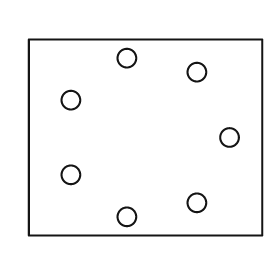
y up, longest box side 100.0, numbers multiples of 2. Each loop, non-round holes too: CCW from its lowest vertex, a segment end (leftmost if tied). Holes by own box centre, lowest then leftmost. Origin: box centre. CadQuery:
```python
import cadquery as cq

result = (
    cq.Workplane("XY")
    .moveTo(-50.0, -42.0)
    .lineTo(50.0, -42.0)
    .lineTo(50.0, 42.0)
    .lineTo(-50.0, 42.0)
    .close()
    .moveTo(-8.0, -34.0)
    .circle(4.0)
    .moveTo(22.0, -28.0)
    .circle(4.0)
    .moveTo(-32.0, -16.0)
    .circle(4.0)
    .moveTo(36.0, 0.0)
    .circle(4.0)
    .moveTo(-32.0, 16.0)
    .circle(4.0)
    .moveTo(22.0, 28.0)
    .circle(4.0)
    .moveTo(-8.0, 34.0)
    .circle(4.0)
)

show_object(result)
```